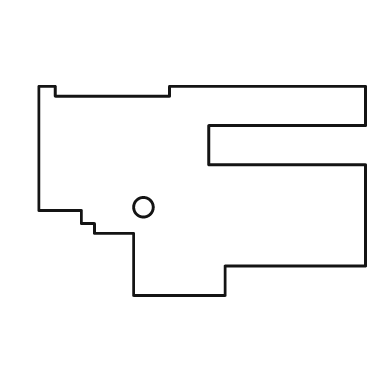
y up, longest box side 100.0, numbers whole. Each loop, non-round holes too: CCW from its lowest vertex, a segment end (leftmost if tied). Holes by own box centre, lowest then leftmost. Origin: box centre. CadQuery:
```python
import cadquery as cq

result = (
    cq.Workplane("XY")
    .moveTo(-21.0, -32.0)
    .lineTo(7.0, -32.0)
    .lineTo(7.0, -23.0)
    .lineTo(50.0, -23.0)
    .lineTo(50.0, 8.0)
    .lineTo(2.0, 8.0)
    .lineTo(2.0, 20.0)
    .lineTo(50.0, 20.0)
    .lineTo(50.0, 32.0)
    .lineTo(-10.0, 32.0)
    .lineTo(-10.0, 29.0)
    .lineTo(-45.0, 29.0)
    .lineTo(-45.0, 32.0)
    .lineTo(-50.0, 32.0)
    .lineTo(-50.0, -6.0)
    .lineTo(-37.0, -6.0)
    .lineTo(-37.0, -10.0)
    .lineTo(-33.0, -10.0)
    .lineTo(-33.0, -13.0)
    .lineTo(-21.0, -13.0)
    .close()
    .moveTo(-18.0, -5.0)
    .circle(3.0)
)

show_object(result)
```